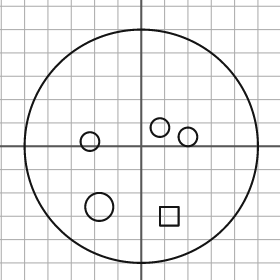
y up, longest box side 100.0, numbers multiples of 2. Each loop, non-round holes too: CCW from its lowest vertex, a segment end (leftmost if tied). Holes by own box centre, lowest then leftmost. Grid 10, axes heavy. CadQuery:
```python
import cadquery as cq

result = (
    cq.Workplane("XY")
    .moveTo(0.0, 0.0)
    .circle(50.0)
    .moveTo(8.0, -34.0)
    .lineTo(16.0, -34.0)
    .lineTo(16.0, -26.0)
    .lineTo(8.0, -26.0)
    .close()
    .moveTo(-18.0, -26.0)
    .circle(6.0)
    .moveTo(-22.0, 2.0)
    .circle(4.0)
    .moveTo(20.0, 4.0)
    .circle(4.0)
    .moveTo(8.0, 8.0)
    .circle(4.0)
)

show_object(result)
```